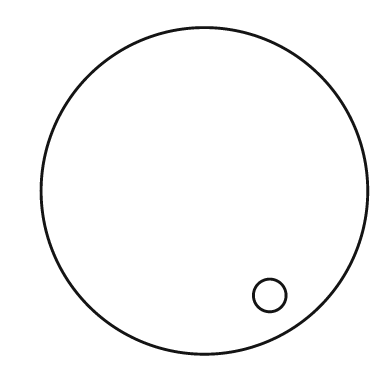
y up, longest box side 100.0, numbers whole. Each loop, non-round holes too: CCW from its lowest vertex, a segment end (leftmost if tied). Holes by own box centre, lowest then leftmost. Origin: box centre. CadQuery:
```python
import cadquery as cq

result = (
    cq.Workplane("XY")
    .moveTo(0.0, 0.0)
    .circle(50.0)
    .moveTo(20.0, -32.0)
    .circle(5.0)
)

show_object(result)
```